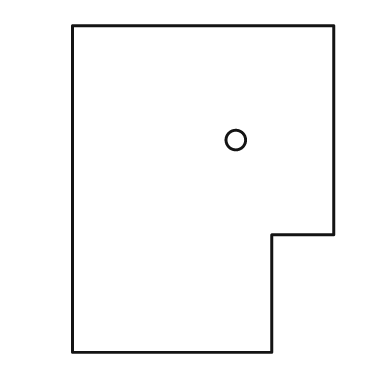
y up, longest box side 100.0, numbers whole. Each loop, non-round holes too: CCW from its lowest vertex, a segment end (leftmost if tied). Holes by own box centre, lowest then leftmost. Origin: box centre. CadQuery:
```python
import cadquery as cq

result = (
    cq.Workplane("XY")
    .moveTo(-40.0, -50.0)
    .lineTo(21.0, -50.0)
    .lineTo(21.0, -14.0)
    .lineTo(40.0, -14.0)
    .lineTo(40.0, 50.0)
    .lineTo(-40.0, 50.0)
    .close()
    .moveTo(10.0, 15.0)
    .circle(3.0)
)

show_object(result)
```